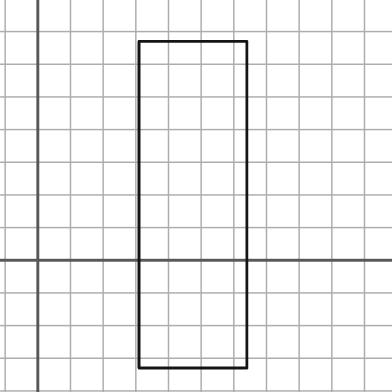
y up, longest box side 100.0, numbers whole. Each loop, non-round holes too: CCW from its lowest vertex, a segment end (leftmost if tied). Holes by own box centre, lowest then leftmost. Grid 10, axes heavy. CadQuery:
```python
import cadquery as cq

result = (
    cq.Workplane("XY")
    .moveTo(31.0, -33.0)
    .lineTo(64.0, -33.0)
    .lineTo(64.0, 67.0)
    .lineTo(31.0, 67.0)
    .close()
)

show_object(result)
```